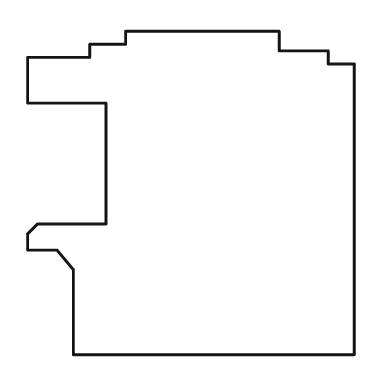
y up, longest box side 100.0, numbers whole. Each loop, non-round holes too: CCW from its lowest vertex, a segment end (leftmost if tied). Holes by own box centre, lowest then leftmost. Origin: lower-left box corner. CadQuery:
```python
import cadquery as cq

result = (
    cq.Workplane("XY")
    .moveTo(14.0, 0.0)
    .lineTo(100.0, 0.0)
    .lineTo(100.0, 89.0)
    .lineTo(92.0, 89.0)
    .lineTo(92.0, 93.0)
    .lineTo(77.0, 93.0)
    .lineTo(77.0, 99.0)
    .lineTo(30.0, 99.0)
    .lineTo(30.0, 95.0)
    .lineTo(19.0, 95.0)
    .lineTo(19.0, 91.0)
    .lineTo(0.0, 91.0)
    .lineTo(0.0, 77.0)
    .lineTo(24.0, 77.0)
    .lineTo(24.0, 40.0)
    .lineTo(3.0, 40.0)
    .lineTo(0.0, 37.0)
    .lineTo(0.0, 32.0)
    .lineTo(9.0, 32.0)
    .lineTo(14.0, 26.0)
    .close()
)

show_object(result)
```